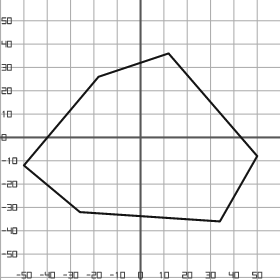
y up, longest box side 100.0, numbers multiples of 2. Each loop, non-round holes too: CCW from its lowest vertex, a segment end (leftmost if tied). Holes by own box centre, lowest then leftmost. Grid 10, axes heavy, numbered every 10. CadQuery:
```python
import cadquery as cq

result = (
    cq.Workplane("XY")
    .moveTo(34.0, -36.0)
    .lineTo(50.0, -8.0)
    .lineTo(12.0, 36.0)
    .lineTo(-18.0, 26.0)
    .lineTo(-50.0, -12.0)
    .lineTo(-26.0, -32.0)
    .close()
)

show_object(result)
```